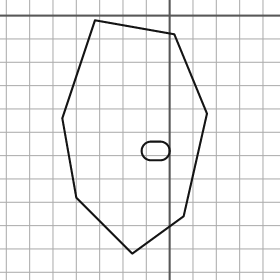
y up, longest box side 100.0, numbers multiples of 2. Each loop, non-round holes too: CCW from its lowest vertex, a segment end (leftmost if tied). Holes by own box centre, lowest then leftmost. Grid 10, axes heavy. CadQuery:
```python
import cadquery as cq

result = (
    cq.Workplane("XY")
    .moveTo(-16.0, -102.0)
    .lineTo(6.0, -86.0)
    .lineTo(16.0, -42.0)
    .lineTo(2.0, -8.0)
    .lineTo(-32.0, -2.0)
    .lineTo(-46.0, -44.0)
    .lineTo(-40.0, -78.0)
    .close()
    .moveTo(-8.0, -62.0)
    .lineTo(-4.0, -62.0)
    .threePointArc((0.0, -58.0), (-4.0, -54.0))
    .lineTo(-8.0, -54.0)
    .threePointArc((-12.0, -58.0), (-8.0, -62.0))
    .close()
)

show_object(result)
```